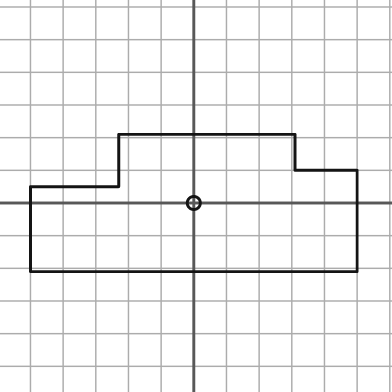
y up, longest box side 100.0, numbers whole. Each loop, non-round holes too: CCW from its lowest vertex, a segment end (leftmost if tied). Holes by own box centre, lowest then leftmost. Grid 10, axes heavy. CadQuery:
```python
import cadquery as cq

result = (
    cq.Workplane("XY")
    .moveTo(-50.0, -21.0)
    .lineTo(50.0, -21.0)
    .lineTo(50.0, 10.0)
    .lineTo(31.0, 10.0)
    .lineTo(31.0, 21.0)
    .lineTo(-23.0, 21.0)
    .lineTo(-23.0, 5.0)
    .lineTo(-50.0, 5.0)
    .close()
    .moveTo(0.0, 0.0)
    .circle(2.0)
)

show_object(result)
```